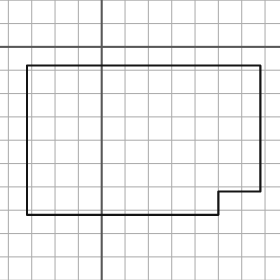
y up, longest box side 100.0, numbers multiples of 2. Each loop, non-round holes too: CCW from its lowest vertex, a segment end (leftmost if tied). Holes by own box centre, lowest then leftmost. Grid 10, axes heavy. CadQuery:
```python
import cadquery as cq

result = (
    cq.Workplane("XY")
    .moveTo(-32.0, -72.0)
    .lineTo(50.0, -72.0)
    .lineTo(50.0, -62.0)
    .lineTo(68.0, -62.0)
    .lineTo(68.0, -8.0)
    .lineTo(-32.0, -8.0)
    .close()
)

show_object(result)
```